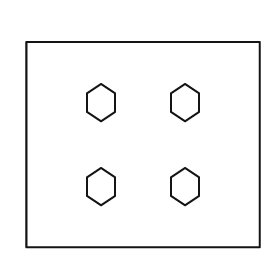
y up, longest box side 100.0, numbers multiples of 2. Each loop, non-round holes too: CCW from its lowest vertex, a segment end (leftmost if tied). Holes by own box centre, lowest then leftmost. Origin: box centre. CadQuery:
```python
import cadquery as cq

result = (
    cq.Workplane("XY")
    .moveTo(-50.0, -44.0)
    .lineTo(50.0, -44.0)
    .lineTo(50.0, 44.0)
    .lineTo(-50.0, 44.0)
    .close()
    .moveTo(-18.0, -26.0)
    .lineTo(-12.0, -22.0)
    .lineTo(-12.0, -14.0)
    .lineTo(-18.0, -10.0)
    .lineTo(-24.0, -14.0)
    .lineTo(-24.0, -22.0)
    .close()
    .moveTo(18.0, -26.0)
    .lineTo(24.0, -22.0)
    .lineTo(24.0, -14.0)
    .lineTo(18.0, -10.0)
    .lineTo(12.0, -14.0)
    .lineTo(12.0, -22.0)
    .close()
    .moveTo(-18.0, 10.0)
    .lineTo(-12.0, 14.0)
    .lineTo(-12.0, 22.0)
    .lineTo(-18.0, 26.0)
    .lineTo(-24.0, 22.0)
    .lineTo(-24.0, 14.0)
    .close()
    .moveTo(18.0, 10.0)
    .lineTo(24.0, 14.0)
    .lineTo(24.0, 22.0)
    .lineTo(18.0, 26.0)
    .lineTo(12.0, 22.0)
    .lineTo(12.0, 14.0)
    .close()
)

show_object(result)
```